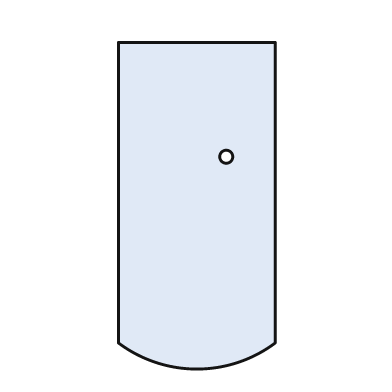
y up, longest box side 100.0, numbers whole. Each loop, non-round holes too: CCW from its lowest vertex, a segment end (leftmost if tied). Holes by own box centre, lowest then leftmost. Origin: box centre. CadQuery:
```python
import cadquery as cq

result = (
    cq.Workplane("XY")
    .moveTo(-24.0, -42.0)
    .threePointArc((0.0, -50.0), (24.0, -42.0))
    .lineTo(24.0, 50.0)
    .lineTo(-24.0, 50.0)
    .close()
    .moveTo(9.0, 15.0)
    .circle(2.0)
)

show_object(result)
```